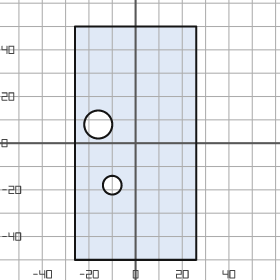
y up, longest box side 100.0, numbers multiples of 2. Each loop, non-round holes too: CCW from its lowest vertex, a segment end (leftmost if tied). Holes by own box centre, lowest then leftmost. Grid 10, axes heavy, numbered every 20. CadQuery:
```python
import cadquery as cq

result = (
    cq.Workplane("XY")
    .moveTo(-26.0, -50.0)
    .lineTo(26.0, -50.0)
    .lineTo(26.0, 50.0)
    .lineTo(-26.0, 50.0)
    .close()
    .moveTo(-10.0, -18.0)
    .circle(4.0)
    .moveTo(-16.0, 8.0)
    .circle(6.0)
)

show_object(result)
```